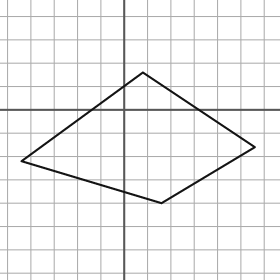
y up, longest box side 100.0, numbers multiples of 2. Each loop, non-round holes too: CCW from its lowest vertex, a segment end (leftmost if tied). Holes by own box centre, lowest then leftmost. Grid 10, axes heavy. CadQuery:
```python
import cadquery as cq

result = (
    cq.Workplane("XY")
    .moveTo(16.0, -40.0)
    .lineTo(56.0, -16.0)
    .lineTo(8.0, 16.0)
    .lineTo(-44.0, -22.0)
    .close()
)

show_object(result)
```